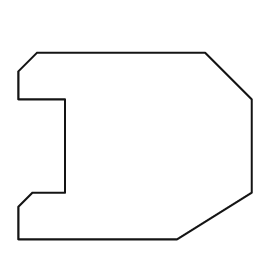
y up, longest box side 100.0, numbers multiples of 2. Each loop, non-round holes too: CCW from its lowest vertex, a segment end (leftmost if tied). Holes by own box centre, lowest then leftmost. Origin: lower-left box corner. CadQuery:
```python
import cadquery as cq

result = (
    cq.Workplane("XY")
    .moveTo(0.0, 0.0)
    .lineTo(68.0, 0.0)
    .lineTo(100.0, 20.0)
    .lineTo(100.0, 60.0)
    .lineTo(80.0, 80.0)
    .lineTo(8.0, 80.0)
    .lineTo(0.0, 72.0)
    .lineTo(0.0, 60.0)
    .lineTo(20.0, 60.0)
    .lineTo(20.0, 20.0)
    .lineTo(6.0, 20.0)
    .lineTo(0.0, 14.0)
    .close()
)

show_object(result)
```